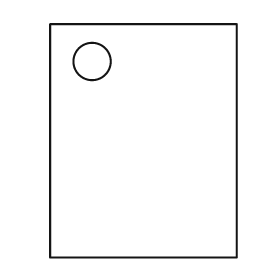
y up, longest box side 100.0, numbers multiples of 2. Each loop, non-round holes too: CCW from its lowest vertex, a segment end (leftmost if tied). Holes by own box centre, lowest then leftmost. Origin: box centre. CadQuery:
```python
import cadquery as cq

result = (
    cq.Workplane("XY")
    .moveTo(-40.0, -50.0)
    .lineTo(40.0, -50.0)
    .lineTo(40.0, 50.0)
    .lineTo(-40.0, 50.0)
    .close()
    .moveTo(-22.0, 34.0)
    .circle(8.0)
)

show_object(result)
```